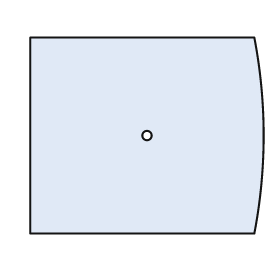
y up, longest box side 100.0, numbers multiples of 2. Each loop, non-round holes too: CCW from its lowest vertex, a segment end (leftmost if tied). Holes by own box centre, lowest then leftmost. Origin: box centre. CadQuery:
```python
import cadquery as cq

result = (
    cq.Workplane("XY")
    .moveTo(-50.0, -42.0)
    .lineTo(46.0, -42.0)
    .threePointArc((50.0, 0.0), (46.0, 42.0))
    .lineTo(-50.0, 42.0)
    .close()
    .moveTo(0.0, 0.0)
    .circle(2.0)
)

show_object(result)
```